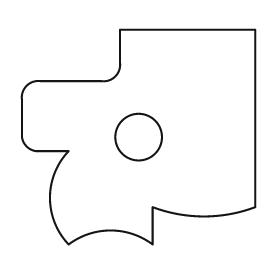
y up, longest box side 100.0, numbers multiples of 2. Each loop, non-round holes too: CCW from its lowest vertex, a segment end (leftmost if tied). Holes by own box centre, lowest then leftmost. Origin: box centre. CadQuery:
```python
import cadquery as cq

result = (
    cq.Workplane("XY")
    .moveTo(-30.0, -46.0)
    .threePointArc((-12.0, -40.0), (6.0, -46.0))
    .lineTo(6.0, -30.0)
    .threePointArc((28.0, -34.0), (50.0, -30.0))
    .lineTo(50.0, 46.0)
    .lineTo(-8.0, 46.0)
    .lineTo(-8.0, 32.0)
    .threePointArc((-10.0, 26.0), (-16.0, 24.0))
    .lineTo(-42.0, 24.0)
    .threePointArc((-48.0, 22.0), (-50.0, 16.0))
    .lineTo(-50.0, 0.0)
    .threePointArc((-48.0, -4.0), (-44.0, -6.0))
    .lineTo(-30.0, -6.0)
    .threePointArc((-38.0, -26.0), (-30.0, -46.0))
    .close()
    .moveTo(0.0, 0.0)
    .circle(10.0)
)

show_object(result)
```